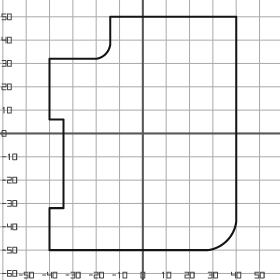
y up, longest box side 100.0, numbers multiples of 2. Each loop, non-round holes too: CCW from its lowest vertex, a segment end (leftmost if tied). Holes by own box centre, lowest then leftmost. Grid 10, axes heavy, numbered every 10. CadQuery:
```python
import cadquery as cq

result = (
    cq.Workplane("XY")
    .moveTo(-40.0, -50.0)
    .lineTo(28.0, -50.0)
    .threePointArc((36.0, -46.0), (40.0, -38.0))
    .lineTo(40.0, 50.0)
    .lineTo(-14.0, 50.0)
    .lineTo(-14.0, 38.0)
    .threePointArc((-16.0, 34.0), (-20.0, 32.0))
    .lineTo(-40.0, 32.0)
    .lineTo(-40.0, 6.0)
    .lineTo(-34.0, 6.0)
    .lineTo(-34.0, -32.0)
    .lineTo(-40.0, -32.0)
    .close()
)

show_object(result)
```